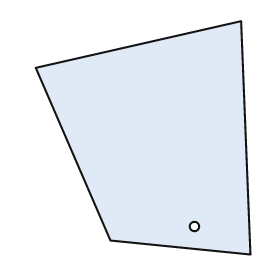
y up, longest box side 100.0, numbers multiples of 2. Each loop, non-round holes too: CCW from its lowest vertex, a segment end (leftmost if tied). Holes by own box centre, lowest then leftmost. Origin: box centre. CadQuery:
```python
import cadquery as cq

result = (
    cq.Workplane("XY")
    .moveTo(46.0, -50.0)
    .lineTo(42.0, 50.0)
    .lineTo(-46.0, 30.0)
    .lineTo(-14.0, -44.0)
    .close()
    .moveTo(22.0, -38.0)
    .circle(2.0)
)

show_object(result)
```